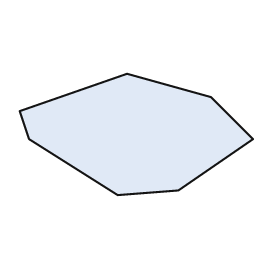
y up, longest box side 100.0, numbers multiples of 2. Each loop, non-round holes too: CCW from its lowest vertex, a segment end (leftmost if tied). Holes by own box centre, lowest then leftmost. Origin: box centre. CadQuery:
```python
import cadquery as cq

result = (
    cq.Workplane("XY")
    .moveTo(-8.0, -26.0)
    .lineTo(18.0, -24.0)
    .lineTo(50.0, -2.0)
    .lineTo(32.0, 16.0)
    .lineTo(-4.0, 26.0)
    .lineTo(-50.0, 10.0)
    .lineTo(-46.0, -2.0)
    .close()
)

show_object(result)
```